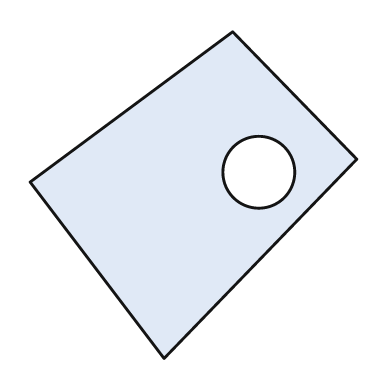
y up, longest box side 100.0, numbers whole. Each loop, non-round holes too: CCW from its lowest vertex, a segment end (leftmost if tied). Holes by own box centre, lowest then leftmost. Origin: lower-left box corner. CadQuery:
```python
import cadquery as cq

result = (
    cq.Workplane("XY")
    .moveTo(41.0, 0.0)
    .lineTo(100.0, 61.0)
    .lineTo(62.0, 100.0)
    .lineTo(0.0, 54.0)
    .close()
    .moveTo(70.0, 57.0)
    .circle(11.0)
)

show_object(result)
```